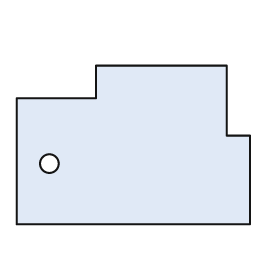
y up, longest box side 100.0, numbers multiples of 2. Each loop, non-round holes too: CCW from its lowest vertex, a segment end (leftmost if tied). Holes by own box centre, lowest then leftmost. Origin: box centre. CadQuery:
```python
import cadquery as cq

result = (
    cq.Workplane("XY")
    .moveTo(-50.0, -34.0)
    .lineTo(50.0, -34.0)
    .lineTo(50.0, 4.0)
    .lineTo(40.0, 4.0)
    .lineTo(40.0, 34.0)
    .lineTo(-16.0, 34.0)
    .lineTo(-16.0, 20.0)
    .lineTo(-50.0, 20.0)
    .close()
    .moveTo(-36.0, -8.0)
    .circle(4.0)
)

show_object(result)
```